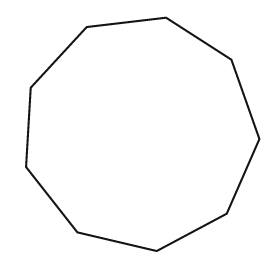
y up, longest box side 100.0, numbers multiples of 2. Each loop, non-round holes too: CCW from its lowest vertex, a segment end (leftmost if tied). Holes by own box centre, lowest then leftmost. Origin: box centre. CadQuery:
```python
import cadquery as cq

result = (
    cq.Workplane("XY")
    .moveTo(6.0, -50.0)
    .lineTo(36.0, -34.0)
    .lineTo(50.0, -2.0)
    .lineTo(38.0, 32.0)
    .lineTo(10.0, 50.0)
    .lineTo(-24.0, 46.0)
    .lineTo(-48.0, 20.0)
    .lineTo(-50.0, -14.0)
    .lineTo(-28.0, -42.0)
    .close()
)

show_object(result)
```